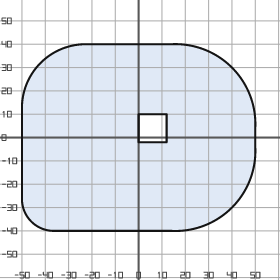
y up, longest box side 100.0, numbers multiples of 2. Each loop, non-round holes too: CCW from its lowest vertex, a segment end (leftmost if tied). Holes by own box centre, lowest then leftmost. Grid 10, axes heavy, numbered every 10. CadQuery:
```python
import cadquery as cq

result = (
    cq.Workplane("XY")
    .moveTo(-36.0, -40.0)
    .lineTo(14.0, -40.0)
    .threePointArc((40.0, -30.0), (50.0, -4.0))
    .lineTo(50.0, 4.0)
    .threePointArc((40.0, 30.0), (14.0, 40.0))
    .lineTo(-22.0, 40.0)
    .threePointArc((-42.0, 32.0), (-50.0, 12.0))
    .lineTo(-50.0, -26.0)
    .threePointArc((-46.0, -36.0), (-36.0, -40.0))
    .close()
    .moveTo(0.0, -2.0)
    .lineTo(12.0, -2.0)
    .lineTo(12.0, 10.0)
    .lineTo(0.0, 10.0)
    .close()
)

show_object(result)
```